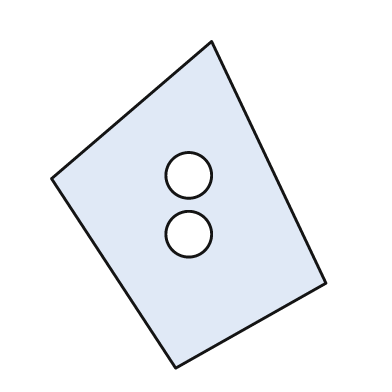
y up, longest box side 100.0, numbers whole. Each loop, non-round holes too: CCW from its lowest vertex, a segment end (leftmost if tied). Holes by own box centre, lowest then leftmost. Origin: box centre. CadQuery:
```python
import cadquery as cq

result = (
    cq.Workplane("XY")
    .moveTo(-4.0, -50.0)
    .lineTo(42.0, -24.0)
    .lineTo(7.0, 50.0)
    .lineTo(-42.0, 8.0)
    .close()
    .moveTo(0.0, -9.0)
    .circle(7.0)
    .moveTo(0.0, 9.0)
    .circle(7.0)
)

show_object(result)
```